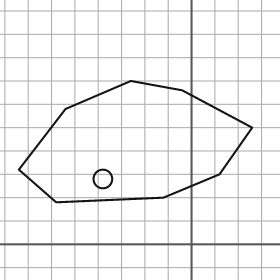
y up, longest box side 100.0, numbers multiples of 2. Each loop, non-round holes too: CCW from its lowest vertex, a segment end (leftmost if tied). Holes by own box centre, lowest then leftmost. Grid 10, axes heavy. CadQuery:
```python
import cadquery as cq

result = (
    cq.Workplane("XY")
    .moveTo(-58.0, 18.0)
    .lineTo(-12.0, 20.0)
    .lineTo(12.0, 30.0)
    .lineTo(26.0, 50.0)
    .lineTo(-4.0, 66.0)
    .lineTo(-26.0, 70.0)
    .lineTo(-54.0, 58.0)
    .lineTo(-74.0, 32.0)
    .close()
    .moveTo(-38.0, 28.0)
    .circle(4.0)
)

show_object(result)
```